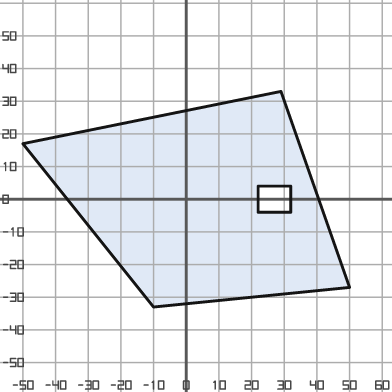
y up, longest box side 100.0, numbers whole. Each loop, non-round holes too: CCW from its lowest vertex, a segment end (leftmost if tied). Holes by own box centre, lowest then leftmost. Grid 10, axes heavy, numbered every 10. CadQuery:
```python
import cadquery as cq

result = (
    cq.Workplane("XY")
    .moveTo(-10.0, -33.0)
    .lineTo(50.0, -27.0)
    .lineTo(29.0, 33.0)
    .lineTo(-50.0, 17.0)
    .close()
    .moveTo(22.0, -4.0)
    .lineTo(32.0, -4.0)
    .lineTo(32.0, 4.0)
    .lineTo(22.0, 4.0)
    .close()
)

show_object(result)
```